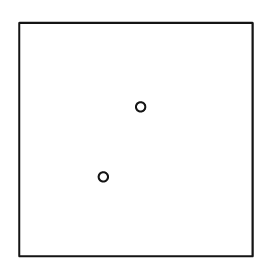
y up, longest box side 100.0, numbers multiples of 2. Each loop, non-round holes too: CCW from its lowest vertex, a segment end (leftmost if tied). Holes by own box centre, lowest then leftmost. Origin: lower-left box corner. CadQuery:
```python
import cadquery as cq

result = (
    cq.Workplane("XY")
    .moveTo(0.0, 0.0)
    .lineTo(100.0, 0.0)
    .lineTo(100.0, 100.0)
    .lineTo(0.0, 100.0)
    .close()
    .moveTo(36.0, 34.0)
    .circle(2.0)
    .moveTo(52.0, 64.0)
    .circle(2.0)
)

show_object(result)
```